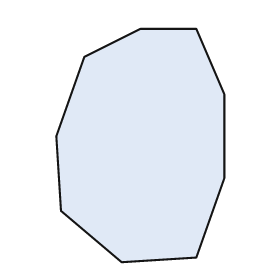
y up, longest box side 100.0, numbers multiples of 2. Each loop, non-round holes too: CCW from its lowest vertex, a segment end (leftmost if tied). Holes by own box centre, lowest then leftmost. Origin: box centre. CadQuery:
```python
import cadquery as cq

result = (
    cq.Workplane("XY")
    .moveTo(-8.0, -50.0)
    .lineTo(24.0, -48.0)
    .lineTo(36.0, -14.0)
    .lineTo(36.0, 22.0)
    .lineTo(24.0, 50.0)
    .lineTo(0.0, 50.0)
    .lineTo(-24.0, 38.0)
    .lineTo(-36.0, 4.0)
    .lineTo(-34.0, -28.0)
    .close()
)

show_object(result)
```